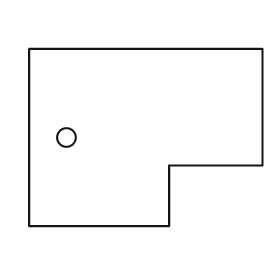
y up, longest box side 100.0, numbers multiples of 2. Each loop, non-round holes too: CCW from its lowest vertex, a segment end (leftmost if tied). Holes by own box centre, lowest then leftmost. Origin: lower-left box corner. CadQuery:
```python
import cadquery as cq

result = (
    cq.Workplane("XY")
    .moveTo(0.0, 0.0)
    .lineTo(60.0, 0.0)
    .lineTo(60.0, 26.0)
    .lineTo(100.0, 26.0)
    .lineTo(100.0, 76.0)
    .lineTo(0.0, 76.0)
    .close()
    .moveTo(16.0, 38.0)
    .circle(4.0)
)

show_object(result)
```